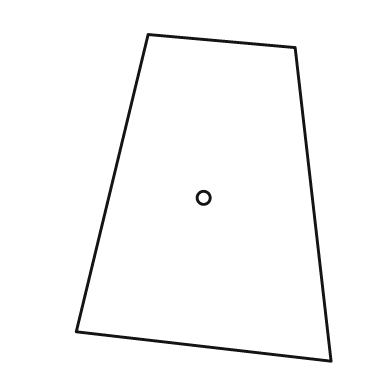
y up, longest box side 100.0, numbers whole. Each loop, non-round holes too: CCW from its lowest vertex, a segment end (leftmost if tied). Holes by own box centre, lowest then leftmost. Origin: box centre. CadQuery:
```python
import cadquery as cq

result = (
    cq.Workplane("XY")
    .moveTo(39.0, -50.0)
    .lineTo(28.0, 46.0)
    .lineTo(-17.0, 50.0)
    .lineTo(-39.0, -41.0)
    .close()
    .moveTo(0.0, 0.0)
    .circle(2.0)
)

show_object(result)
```